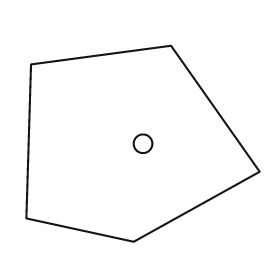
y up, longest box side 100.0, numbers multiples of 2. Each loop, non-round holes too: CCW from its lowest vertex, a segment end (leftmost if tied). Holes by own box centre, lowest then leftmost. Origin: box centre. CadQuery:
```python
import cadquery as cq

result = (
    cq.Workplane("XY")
    .moveTo(-4.0, -42.0)
    .lineTo(50.0, -12.0)
    .lineTo(12.0, 42.0)
    .lineTo(-48.0, 34.0)
    .lineTo(-50.0, -32.0)
    .close()
    .moveTo(0.0, 0.0)
    .circle(4.0)
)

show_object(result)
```